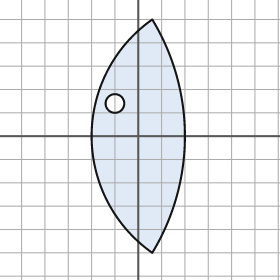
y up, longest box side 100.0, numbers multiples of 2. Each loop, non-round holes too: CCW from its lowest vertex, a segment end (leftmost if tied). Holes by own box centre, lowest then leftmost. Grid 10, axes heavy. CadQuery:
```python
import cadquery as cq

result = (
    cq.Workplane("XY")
    .moveTo(6.0, -50.0)
    .threePointArc((20.0, 0.0), (6.0, 50.0))
    .threePointArc((-20.0, 0.0), (6.0, -50.0))
    .close()
    .moveTo(-10.0, 14.0)
    .circle(4.0)
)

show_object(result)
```